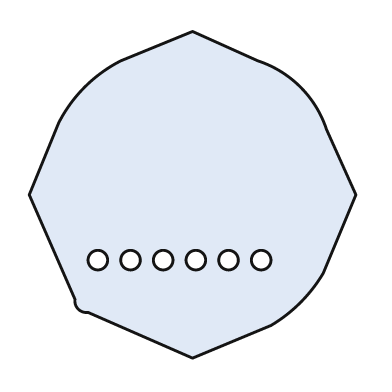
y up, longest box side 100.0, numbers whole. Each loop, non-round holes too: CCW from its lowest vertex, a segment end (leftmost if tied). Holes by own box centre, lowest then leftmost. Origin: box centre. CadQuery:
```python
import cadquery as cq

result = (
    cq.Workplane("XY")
    .moveTo(0.0, -50.0)
    .lineTo(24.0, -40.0)
    .threePointArc((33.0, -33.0), (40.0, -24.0))
    .lineTo(50.0, 0.0)
    .lineTo(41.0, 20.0)
    .threePointArc((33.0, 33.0), (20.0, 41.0))
    .lineTo(0.0, 50.0)
    .lineTo(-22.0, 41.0)
    .threePointArc((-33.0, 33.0), (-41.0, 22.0))
    .lineTo(-50.0, 0.0)
    .lineTo(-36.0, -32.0)
    .threePointArc((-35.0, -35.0), (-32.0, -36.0))
    .close()
    .moveTo(-29.0, -20.0)
    .circle(3.0)
    .moveTo(-19.0, -20.0)
    .circle(3.0)
    .moveTo(-9.0, -20.0)
    .circle(3.0)
    .moveTo(1.0, -20.0)
    .circle(3.0)
    .moveTo(11.0, -20.0)
    .circle(3.0)
    .moveTo(21.0, -20.0)
    .circle(3.0)
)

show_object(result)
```